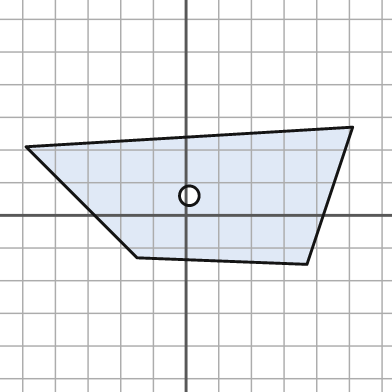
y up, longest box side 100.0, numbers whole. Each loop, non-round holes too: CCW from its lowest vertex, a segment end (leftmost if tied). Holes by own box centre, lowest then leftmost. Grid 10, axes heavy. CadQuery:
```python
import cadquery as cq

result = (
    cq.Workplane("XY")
    .moveTo(37.0, -15.0)
    .lineTo(51.0, 27.0)
    .lineTo(-49.0, 21.0)
    .lineTo(-15.0, -13.0)
    .close()
    .moveTo(1.0, 6.0)
    .circle(3.0)
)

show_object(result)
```